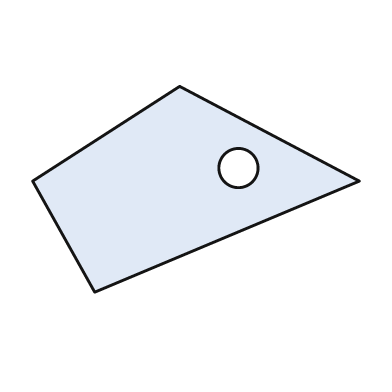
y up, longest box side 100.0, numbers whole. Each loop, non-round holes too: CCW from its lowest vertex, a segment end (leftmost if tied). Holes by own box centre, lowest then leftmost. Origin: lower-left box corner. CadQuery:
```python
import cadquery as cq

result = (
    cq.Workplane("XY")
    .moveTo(19.0, 0.0)
    .lineTo(100.0, 34.0)
    .lineTo(45.0, 63.0)
    .lineTo(0.0, 34.0)
    .close()
    .moveTo(63.0, 38.0)
    .circle(6.0)
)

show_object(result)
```